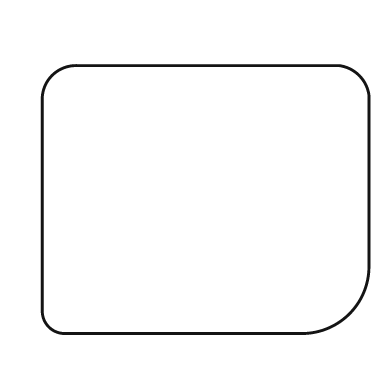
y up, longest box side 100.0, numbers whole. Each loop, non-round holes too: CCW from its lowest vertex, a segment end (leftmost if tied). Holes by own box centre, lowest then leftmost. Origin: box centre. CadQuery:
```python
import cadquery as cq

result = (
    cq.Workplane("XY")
    .moveTo(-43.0, -41.0)
    .lineTo(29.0, -41.0)
    .threePointArc((44.0, -35.0), (50.0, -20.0))
    .lineTo(50.0, 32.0)
    .threePointArc((47.0, 38.0), (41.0, 41.0))
    .lineTo(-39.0, 41.0)
    .threePointArc((-47.0, 38.0), (-50.0, 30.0))
    .lineTo(-50.0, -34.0)
    .threePointArc((-48.0, -39.0), (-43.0, -41.0))
    .close()
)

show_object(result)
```